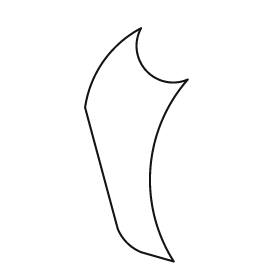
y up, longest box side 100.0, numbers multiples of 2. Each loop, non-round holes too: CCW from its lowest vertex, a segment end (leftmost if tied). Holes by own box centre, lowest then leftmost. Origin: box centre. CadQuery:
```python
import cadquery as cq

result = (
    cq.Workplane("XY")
    .moveTo(16.0, -50.0)
    .threePointArc((6.0, -10.0), (22.0, 28.0))
    .threePointArc((4.0, 32.0), (2.0, 50.0))
    .threePointArc((-14.0, 36.0), (-22.0, 16.0))
    .lineTo(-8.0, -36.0)
    .threePointArc((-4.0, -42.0), (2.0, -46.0))
    .close()
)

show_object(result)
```